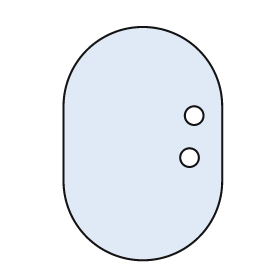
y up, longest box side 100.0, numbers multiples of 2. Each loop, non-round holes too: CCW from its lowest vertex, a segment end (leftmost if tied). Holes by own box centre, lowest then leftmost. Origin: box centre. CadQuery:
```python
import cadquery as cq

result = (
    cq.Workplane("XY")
    .moveTo(-34.0, -16.0)
    .threePointArc((0.0, -50.0), (34.0, -16.0))
    .lineTo(34.0, 16.0)
    .threePointArc((0.0, 50.0), (-34.0, 16.0))
    .close()
    .moveTo(20.0, -6.0)
    .circle(4.0)
    .moveTo(22.0, 12.0)
    .circle(4.0)
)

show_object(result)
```